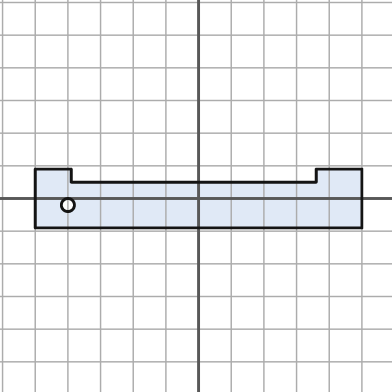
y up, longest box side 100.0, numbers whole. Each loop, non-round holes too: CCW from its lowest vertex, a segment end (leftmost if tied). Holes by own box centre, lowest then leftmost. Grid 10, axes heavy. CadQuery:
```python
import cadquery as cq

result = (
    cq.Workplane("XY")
    .moveTo(-50.0, -9.0)
    .lineTo(50.0, -9.0)
    .lineTo(50.0, 9.0)
    .lineTo(36.0, 9.0)
    .lineTo(36.0, 5.0)
    .lineTo(-39.0, 5.0)
    .lineTo(-39.0, 9.0)
    .lineTo(-50.0, 9.0)
    .close()
    .moveTo(-40.0, -2.0)
    .circle(2.0)
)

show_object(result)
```